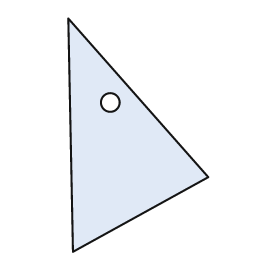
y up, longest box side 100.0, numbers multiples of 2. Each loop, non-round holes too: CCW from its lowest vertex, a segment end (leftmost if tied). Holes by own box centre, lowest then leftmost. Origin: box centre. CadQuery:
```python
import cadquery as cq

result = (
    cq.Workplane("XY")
    .moveTo(-28.0, -50.0)
    .lineTo(30.0, -18.0)
    .lineTo(-30.0, 50.0)
    .close()
    .moveTo(-12.0, 14.0)
    .circle(4.0)
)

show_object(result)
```